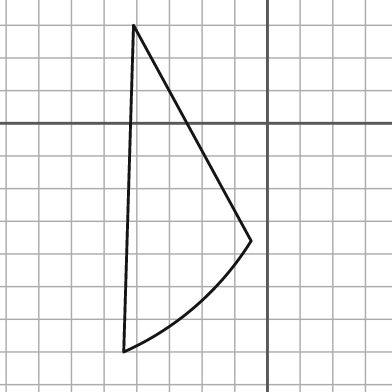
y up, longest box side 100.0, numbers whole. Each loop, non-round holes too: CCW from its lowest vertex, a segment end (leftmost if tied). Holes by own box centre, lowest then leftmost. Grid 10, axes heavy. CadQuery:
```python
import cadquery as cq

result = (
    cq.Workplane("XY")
    .moveTo(-44.0, -70.0)
    .threePointArc((-22.0, -56.0), (-5.0, -36.0))
    .lineTo(-41.0, 30.0)
    .close()
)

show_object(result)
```